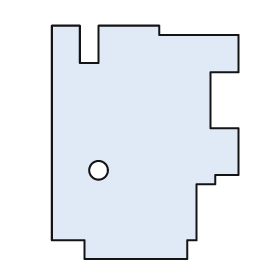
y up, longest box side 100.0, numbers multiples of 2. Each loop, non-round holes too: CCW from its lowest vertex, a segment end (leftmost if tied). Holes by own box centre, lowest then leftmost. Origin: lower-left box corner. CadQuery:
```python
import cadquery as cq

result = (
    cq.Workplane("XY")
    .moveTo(14.0, 0.0)
    .lineTo(58.0, 0.0)
    .lineTo(58.0, 8.0)
    .lineTo(62.0, 8.0)
    .lineTo(62.0, 32.0)
    .lineTo(70.0, 32.0)
    .lineTo(70.0, 36.0)
    .lineTo(80.0, 36.0)
    .lineTo(80.0, 56.0)
    .lineTo(68.0, 56.0)
    .lineTo(68.0, 80.0)
    .lineTo(80.0, 80.0)
    .lineTo(80.0, 96.0)
    .lineTo(46.0, 96.0)
    .lineTo(46.0, 100.0)
    .lineTo(20.0, 100.0)
    .lineTo(20.0, 84.0)
    .lineTo(12.0, 84.0)
    .lineTo(12.0, 100.0)
    .lineTo(0.0, 100.0)
    .lineTo(0.0, 8.0)
    .lineTo(14.0, 8.0)
    .close()
    .moveTo(20.0, 38.0)
    .circle(4.0)
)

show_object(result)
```